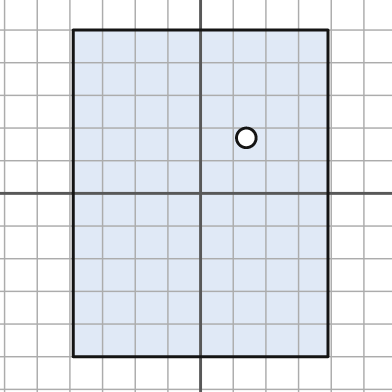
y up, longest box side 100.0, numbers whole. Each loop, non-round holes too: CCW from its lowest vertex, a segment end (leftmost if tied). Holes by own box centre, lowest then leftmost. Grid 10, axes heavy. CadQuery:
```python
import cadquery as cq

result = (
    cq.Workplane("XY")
    .moveTo(-39.0, -50.0)
    .lineTo(39.0, -50.0)
    .lineTo(39.0, 50.0)
    .lineTo(-39.0, 50.0)
    .close()
    .moveTo(14.0, 17.0)
    .circle(3.0)
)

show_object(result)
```